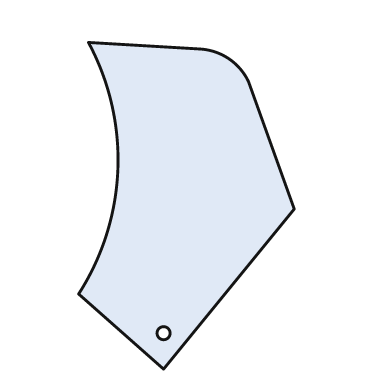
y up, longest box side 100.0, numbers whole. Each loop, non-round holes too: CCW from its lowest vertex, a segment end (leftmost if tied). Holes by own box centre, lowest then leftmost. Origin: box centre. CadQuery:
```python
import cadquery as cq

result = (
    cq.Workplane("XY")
    .moveTo(-7.0, -50.0)
    .lineTo(33.0, -1.0)
    .lineTo(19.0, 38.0)
    .threePointArc((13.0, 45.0), (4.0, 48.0))
    .lineTo(-30.0, 50.0)
    .threePointArc((-21.0, 11.0), (-33.0, -27.0))
    .close()
    .moveTo(-7.0, -39.0)
    .circle(2.0)
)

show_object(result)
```